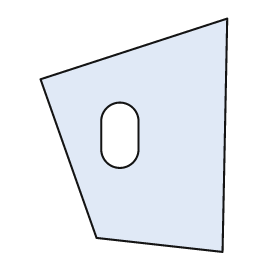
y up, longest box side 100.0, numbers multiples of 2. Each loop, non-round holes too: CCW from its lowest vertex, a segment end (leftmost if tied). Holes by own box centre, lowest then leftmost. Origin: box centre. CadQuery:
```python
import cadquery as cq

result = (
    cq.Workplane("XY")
    .moveTo(38.0, -50.0)
    .lineTo(40.0, 50.0)
    .lineTo(-40.0, 24.0)
    .lineTo(-16.0, -44.0)
    .close()
    .moveTo(-14.0, -6.0)
    .threePointArc((-6.0, -14.0), (2.0, -6.0))
    .lineTo(2.0, 6.0)
    .threePointArc((-6.0, 14.0), (-14.0, 6.0))
    .close()
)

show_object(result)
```